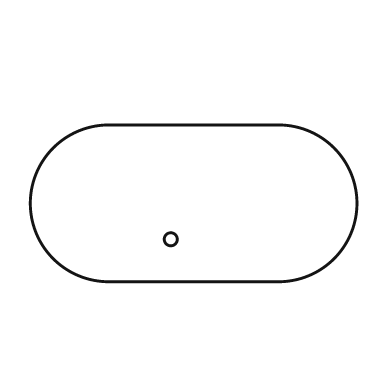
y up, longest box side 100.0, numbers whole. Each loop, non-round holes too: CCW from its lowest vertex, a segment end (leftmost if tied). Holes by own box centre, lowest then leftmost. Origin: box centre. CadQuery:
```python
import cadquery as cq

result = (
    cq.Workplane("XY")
    .moveTo(-26.0, -24.0)
    .lineTo(26.0, -24.0)
    .threePointArc((50.0, 0.0), (26.0, 24.0))
    .lineTo(-26.0, 24.0)
    .threePointArc((-50.0, 0.0), (-26.0, -24.0))
    .close()
    .moveTo(-7.0, -11.0)
    .circle(2.0)
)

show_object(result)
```